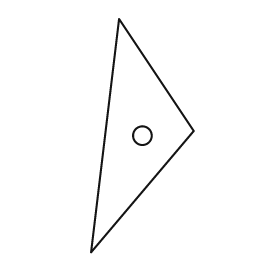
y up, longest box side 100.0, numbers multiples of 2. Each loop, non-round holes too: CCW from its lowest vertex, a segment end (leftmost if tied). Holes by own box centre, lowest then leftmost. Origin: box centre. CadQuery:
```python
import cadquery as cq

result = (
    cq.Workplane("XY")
    .moveTo(-22.0, -50.0)
    .lineTo(22.0, 2.0)
    .lineTo(-10.0, 50.0)
    .close()
    .moveTo(0.0, 0.0)
    .circle(4.0)
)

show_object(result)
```